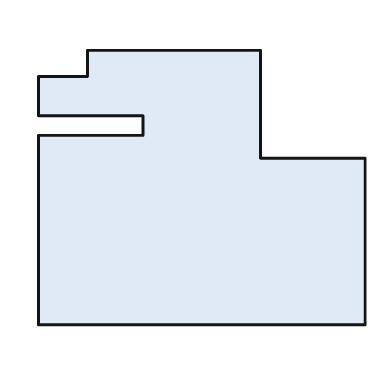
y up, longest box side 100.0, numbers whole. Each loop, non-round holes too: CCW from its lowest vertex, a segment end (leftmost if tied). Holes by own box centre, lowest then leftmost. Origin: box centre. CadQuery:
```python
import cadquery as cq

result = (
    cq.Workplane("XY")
    .moveTo(-50.0, -42.0)
    .lineTo(50.0, -42.0)
    .lineTo(50.0, 9.0)
    .lineTo(18.0, 9.0)
    .lineTo(18.0, 42.0)
    .lineTo(-35.0, 42.0)
    .lineTo(-35.0, 34.0)
    .lineTo(-50.0, 34.0)
    .lineTo(-50.0, 22.0)
    .lineTo(-18.0, 22.0)
    .lineTo(-18.0, 16.0)
    .lineTo(-50.0, 16.0)
    .close()
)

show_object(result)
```